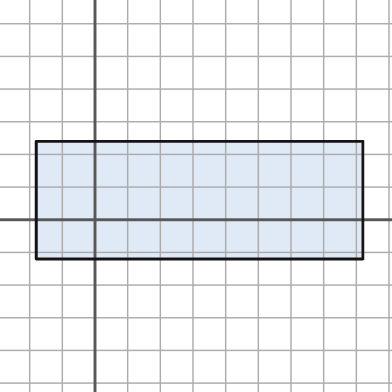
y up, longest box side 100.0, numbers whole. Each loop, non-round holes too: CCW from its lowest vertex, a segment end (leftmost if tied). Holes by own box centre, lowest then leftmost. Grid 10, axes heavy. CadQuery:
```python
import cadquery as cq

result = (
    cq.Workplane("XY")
    .moveTo(-18.0, -12.0)
    .lineTo(82.0, -12.0)
    .lineTo(82.0, 24.0)
    .lineTo(-18.0, 24.0)
    .close()
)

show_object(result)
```